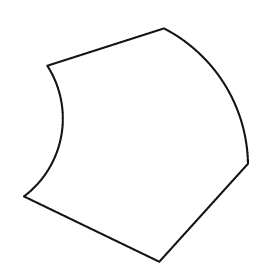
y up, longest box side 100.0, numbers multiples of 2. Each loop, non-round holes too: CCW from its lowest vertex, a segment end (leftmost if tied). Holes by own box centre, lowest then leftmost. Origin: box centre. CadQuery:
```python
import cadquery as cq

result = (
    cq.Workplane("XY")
    .moveTo(10.0, -50.0)
    .lineTo(48.0, -8.0)
    .threePointArc((38.0, 26.0), (12.0, 50.0))
    .lineTo(-38.0, 34.0)
    .threePointArc((-32.0, 4.0), (-48.0, -22.0))
    .close()
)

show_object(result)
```